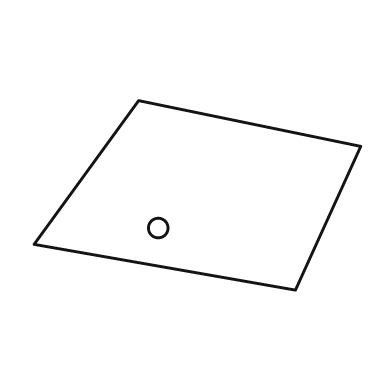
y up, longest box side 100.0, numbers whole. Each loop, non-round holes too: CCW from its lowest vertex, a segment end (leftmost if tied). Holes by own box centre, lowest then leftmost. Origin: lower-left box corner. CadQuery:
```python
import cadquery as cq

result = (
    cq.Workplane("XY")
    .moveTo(80.0, 0.0)
    .lineTo(100.0, 44.0)
    .lineTo(32.0, 58.0)
    .lineTo(0.0, 14.0)
    .close()
    .moveTo(38.0, 19.0)
    .circle(3.0)
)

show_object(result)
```